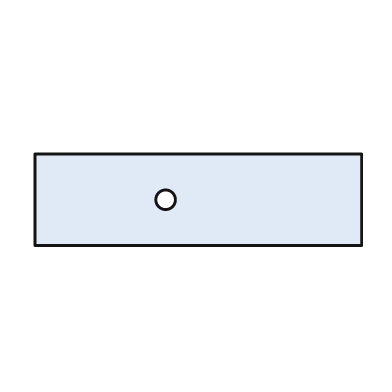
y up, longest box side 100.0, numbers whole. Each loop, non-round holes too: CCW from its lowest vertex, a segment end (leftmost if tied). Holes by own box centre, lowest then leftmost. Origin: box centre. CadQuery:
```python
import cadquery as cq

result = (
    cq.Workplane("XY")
    .moveTo(-50.0, -14.0)
    .lineTo(50.0, -14.0)
    .lineTo(50.0, 14.0)
    .lineTo(-50.0, 14.0)
    .close()
    .moveTo(-10.0, 0.0)
    .circle(3.0)
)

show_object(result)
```